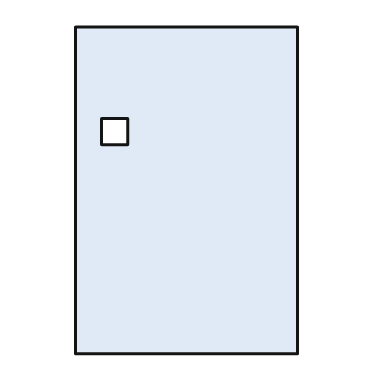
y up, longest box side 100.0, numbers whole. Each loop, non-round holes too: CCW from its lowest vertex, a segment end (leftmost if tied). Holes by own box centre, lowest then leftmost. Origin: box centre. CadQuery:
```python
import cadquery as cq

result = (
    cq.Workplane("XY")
    .moveTo(-34.0, -50.0)
    .lineTo(34.0, -50.0)
    .lineTo(34.0, 50.0)
    .lineTo(-34.0, 50.0)
    .close()
    .moveTo(-26.0, 14.0)
    .lineTo(-18.0, 14.0)
    .lineTo(-18.0, 22.0)
    .lineTo(-26.0, 22.0)
    .close()
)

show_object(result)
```